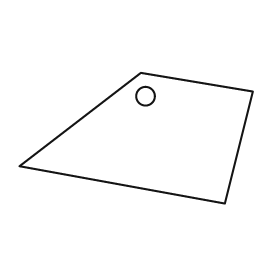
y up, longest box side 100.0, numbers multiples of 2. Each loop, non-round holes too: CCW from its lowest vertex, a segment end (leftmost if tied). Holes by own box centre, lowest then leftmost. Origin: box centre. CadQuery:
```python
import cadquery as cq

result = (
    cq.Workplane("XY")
    .moveTo(38.0, -28.0)
    .lineTo(50.0, 20.0)
    .lineTo(2.0, 28.0)
    .lineTo(-50.0, -12.0)
    .close()
    .moveTo(4.0, 18.0)
    .circle(4.0)
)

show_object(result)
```